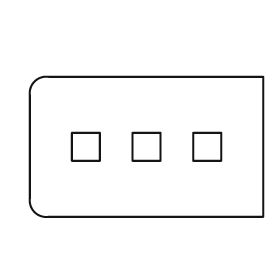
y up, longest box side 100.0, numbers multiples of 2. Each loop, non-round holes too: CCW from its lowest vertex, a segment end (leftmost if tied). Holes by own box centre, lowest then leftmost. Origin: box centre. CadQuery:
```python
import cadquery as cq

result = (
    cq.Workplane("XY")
    .moveTo(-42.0, -30.0)
    .lineTo(50.0, -30.0)
    .lineTo(50.0, 30.0)
    .lineTo(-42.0, 30.0)
    .threePointArc((-48.0, 28.0), (-50.0, 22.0))
    .lineTo(-50.0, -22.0)
    .threePointArc((-48.0, -28.0), (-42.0, -30.0))
    .close()
    .moveTo(-32.0, -6.0)
    .lineTo(-20.0, -6.0)
    .lineTo(-20.0, 6.0)
    .lineTo(-32.0, 6.0)
    .close()
    .moveTo(-6.0, -6.0)
    .lineTo(6.0, -6.0)
    .lineTo(6.0, 6.0)
    .lineTo(-6.0, 6.0)
    .close()
    .moveTo(20.0, -6.0)
    .lineTo(32.0, -6.0)
    .lineTo(32.0, 6.0)
    .lineTo(20.0, 6.0)
    .close()
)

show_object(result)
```